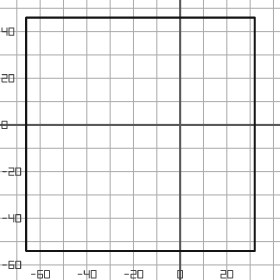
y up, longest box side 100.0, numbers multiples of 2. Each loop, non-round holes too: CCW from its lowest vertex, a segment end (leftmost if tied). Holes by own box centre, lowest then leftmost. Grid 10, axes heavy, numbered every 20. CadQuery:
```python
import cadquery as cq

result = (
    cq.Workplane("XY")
    .moveTo(-66.0, -54.0)
    .lineTo(32.0, -54.0)
    .lineTo(32.0, 46.0)
    .lineTo(-66.0, 46.0)
    .close()
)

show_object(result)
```